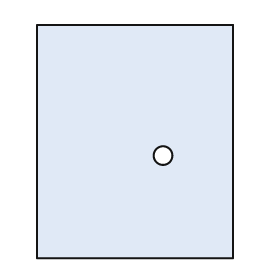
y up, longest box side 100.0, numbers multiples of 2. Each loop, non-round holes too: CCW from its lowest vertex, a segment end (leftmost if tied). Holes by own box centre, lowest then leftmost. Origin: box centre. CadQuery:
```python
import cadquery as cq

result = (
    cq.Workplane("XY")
    .moveTo(-42.0, -50.0)
    .lineTo(42.0, -50.0)
    .lineTo(42.0, 50.0)
    .lineTo(-42.0, 50.0)
    .close()
    .moveTo(12.0, -6.0)
    .circle(4.0)
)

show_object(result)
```